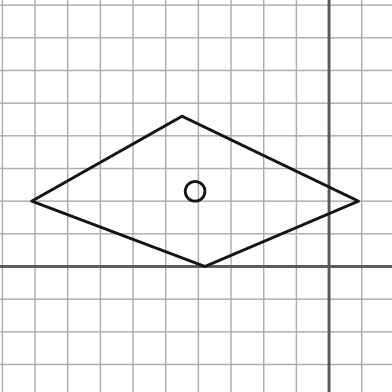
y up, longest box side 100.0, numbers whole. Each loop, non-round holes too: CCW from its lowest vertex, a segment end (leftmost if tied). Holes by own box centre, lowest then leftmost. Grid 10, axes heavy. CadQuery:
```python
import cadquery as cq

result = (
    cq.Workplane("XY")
    .moveTo(-38.0, 0.0)
    .lineTo(9.0, 20.0)
    .lineTo(-45.0, 46.0)
    .lineTo(-91.0, 20.0)
    .close()
    .moveTo(-41.0, 23.0)
    .circle(3.0)
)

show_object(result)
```